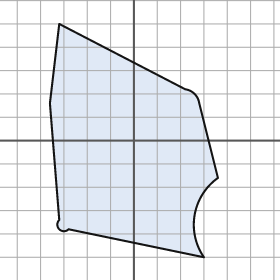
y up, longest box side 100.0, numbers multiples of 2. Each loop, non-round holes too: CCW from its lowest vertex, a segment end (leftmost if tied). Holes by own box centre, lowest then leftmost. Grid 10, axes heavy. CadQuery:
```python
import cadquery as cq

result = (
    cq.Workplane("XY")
    .moveTo(30.0, -50.0)
    .threePointArc((26.0, -32.0), (36.0, -16.0))
    .lineTo(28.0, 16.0)
    .threePointArc((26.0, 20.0), (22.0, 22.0))
    .lineTo(-32.0, 50.0)
    .lineTo(-36.0, 16.0)
    .lineTo(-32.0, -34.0)
    .threePointArc((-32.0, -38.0), (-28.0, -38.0))
    .close()
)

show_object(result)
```